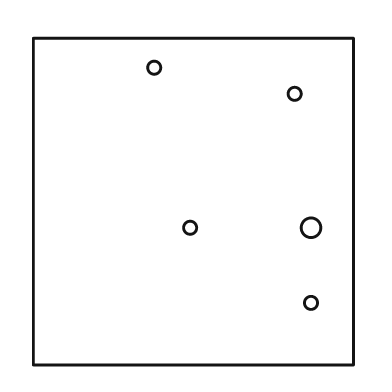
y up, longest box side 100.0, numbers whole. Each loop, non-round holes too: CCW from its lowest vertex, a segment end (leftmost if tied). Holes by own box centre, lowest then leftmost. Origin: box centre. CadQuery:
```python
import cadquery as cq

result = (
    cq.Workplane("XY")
    .moveTo(-49.0, -50.0)
    .lineTo(49.0, -50.0)
    .lineTo(49.0, 50.0)
    .lineTo(-49.0, 50.0)
    .close()
    .moveTo(36.0, -31.0)
    .circle(2.0)
    .moveTo(-1.0, -8.0)
    .circle(2.0)
    .moveTo(36.0, -8.0)
    .circle(3.0)
    .moveTo(31.0, 33.0)
    .circle(2.0)
    .moveTo(-12.0, 41.0)
    .circle(2.0)
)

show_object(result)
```